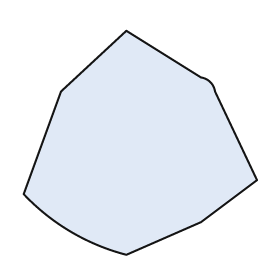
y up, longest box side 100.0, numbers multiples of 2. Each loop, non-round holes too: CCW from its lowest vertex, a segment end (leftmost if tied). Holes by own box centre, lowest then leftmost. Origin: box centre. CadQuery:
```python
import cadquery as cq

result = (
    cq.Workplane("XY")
    .moveTo(-6.0, -48.0)
    .lineTo(26.0, -34.0)
    .lineTo(50.0, -16.0)
    .lineTo(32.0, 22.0)
    .threePointArc((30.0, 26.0), (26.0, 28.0))
    .lineTo(-6.0, 48.0)
    .lineTo(-34.0, 22.0)
    .lineTo(-50.0, -22.0)
    .threePointArc((-30.0, -38.0), (-6.0, -48.0))
    .close()
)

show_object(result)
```